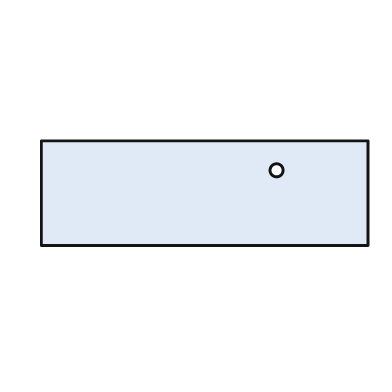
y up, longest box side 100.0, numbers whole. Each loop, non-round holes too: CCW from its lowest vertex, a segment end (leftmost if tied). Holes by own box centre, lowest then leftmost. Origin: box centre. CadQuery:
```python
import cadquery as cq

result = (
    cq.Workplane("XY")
    .moveTo(-50.0, -16.0)
    .lineTo(50.0, -16.0)
    .lineTo(50.0, 16.0)
    .lineTo(-50.0, 16.0)
    .close()
    .moveTo(22.0, 7.0)
    .circle(2.0)
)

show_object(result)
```